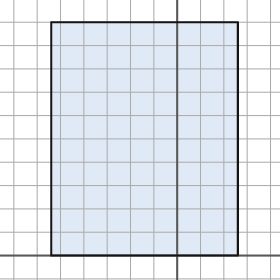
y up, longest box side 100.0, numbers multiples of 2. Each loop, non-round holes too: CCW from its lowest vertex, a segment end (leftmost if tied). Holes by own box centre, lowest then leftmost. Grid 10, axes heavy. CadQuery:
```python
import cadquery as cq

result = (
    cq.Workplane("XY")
    .moveTo(-54.0, 0.0)
    .lineTo(26.0, 0.0)
    .lineTo(26.0, 100.0)
    .lineTo(-54.0, 100.0)
    .close()
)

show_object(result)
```